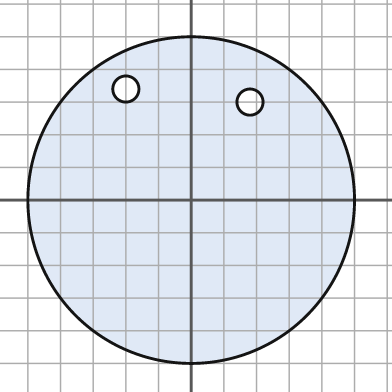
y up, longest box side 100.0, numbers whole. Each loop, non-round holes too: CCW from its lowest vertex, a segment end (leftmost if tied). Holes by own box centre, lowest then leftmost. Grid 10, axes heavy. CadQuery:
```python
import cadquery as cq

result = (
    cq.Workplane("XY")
    .moveTo(0.0, 0.0)
    .circle(50.0)
    .moveTo(18.0, 30.0)
    .circle(4.0)
    .moveTo(-20.0, 34.0)
    .circle(4.0)
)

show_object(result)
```